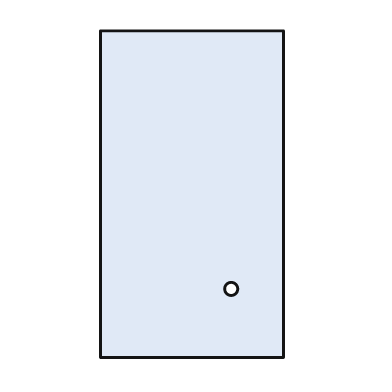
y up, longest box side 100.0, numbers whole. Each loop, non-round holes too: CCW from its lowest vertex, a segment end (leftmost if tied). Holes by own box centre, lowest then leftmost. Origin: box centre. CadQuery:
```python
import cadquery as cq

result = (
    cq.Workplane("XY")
    .moveTo(-28.0, -50.0)
    .lineTo(28.0, -50.0)
    .lineTo(28.0, 50.0)
    .lineTo(-28.0, 50.0)
    .close()
    .moveTo(12.0, -29.0)
    .circle(2.0)
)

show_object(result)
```